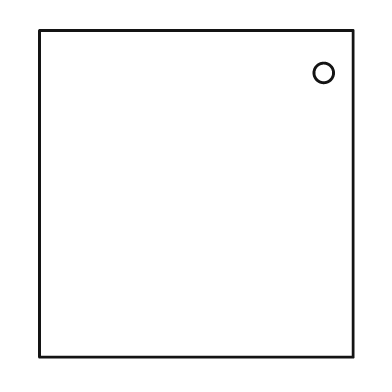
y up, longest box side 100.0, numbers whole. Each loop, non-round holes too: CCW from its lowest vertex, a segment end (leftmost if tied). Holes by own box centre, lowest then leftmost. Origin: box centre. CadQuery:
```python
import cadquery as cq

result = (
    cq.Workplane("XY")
    .moveTo(-48.0, -50.0)
    .lineTo(48.0, -50.0)
    .lineTo(48.0, 50.0)
    .lineTo(-48.0, 50.0)
    .close()
    .moveTo(39.0, 37.0)
    .circle(3.0)
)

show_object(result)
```